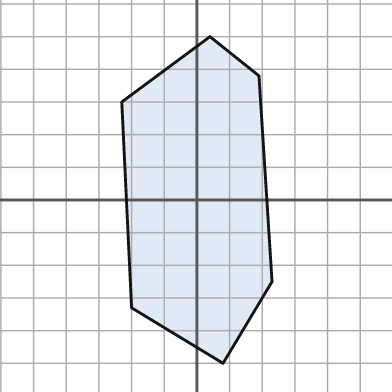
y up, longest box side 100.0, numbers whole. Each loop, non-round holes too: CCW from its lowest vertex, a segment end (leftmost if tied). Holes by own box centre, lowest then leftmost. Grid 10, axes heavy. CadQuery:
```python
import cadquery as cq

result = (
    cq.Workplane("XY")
    .moveTo(8.0, -50.0)
    .lineTo(23.0, -25.0)
    .lineTo(19.0, 38.0)
    .lineTo(4.0, 50.0)
    .lineTo(-23.0, 30.0)
    .lineTo(-20.0, -33.0)
    .close()
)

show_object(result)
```